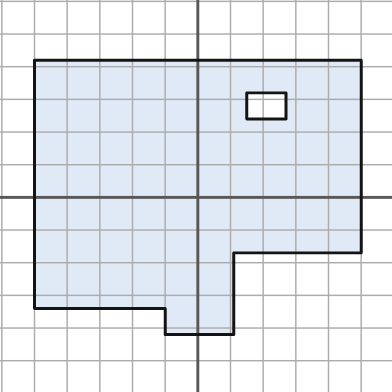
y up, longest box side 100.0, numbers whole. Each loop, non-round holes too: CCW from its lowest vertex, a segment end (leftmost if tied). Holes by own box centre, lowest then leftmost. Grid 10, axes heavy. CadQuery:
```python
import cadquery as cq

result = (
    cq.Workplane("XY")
    .moveTo(-10.0, -42.0)
    .lineTo(11.0, -42.0)
    .lineTo(11.0, -17.0)
    .lineTo(50.0, -17.0)
    .lineTo(50.0, 42.0)
    .lineTo(-50.0, 42.0)
    .lineTo(-50.0, -34.0)
    .lineTo(-10.0, -34.0)
    .close()
    .moveTo(15.0, 24.0)
    .lineTo(27.0, 24.0)
    .lineTo(27.0, 32.0)
    .lineTo(15.0, 32.0)
    .close()
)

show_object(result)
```